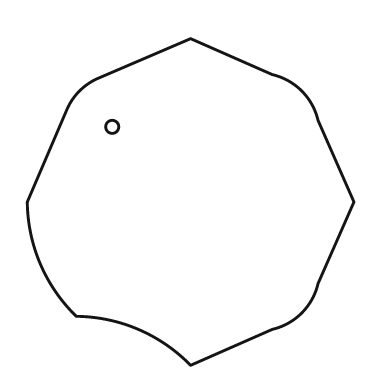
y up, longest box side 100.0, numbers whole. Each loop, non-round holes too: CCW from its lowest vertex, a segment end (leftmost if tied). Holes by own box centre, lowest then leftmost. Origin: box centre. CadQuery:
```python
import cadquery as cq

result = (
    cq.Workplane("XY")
    .moveTo(0.0, -50.0)
    .lineTo(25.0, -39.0)
    .threePointArc((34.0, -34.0), (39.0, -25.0))
    .lineTo(50.0, 0.0)
    .lineTo(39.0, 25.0)
    .threePointArc((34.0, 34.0), (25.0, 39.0))
    .lineTo(0.0, 50.0)
    .lineTo(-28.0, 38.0)
    .threePointArc((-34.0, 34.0), (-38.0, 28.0))
    .lineTo(-50.0, 0.0)
    .threePointArc((-46.0, -19.0), (-35.0, -35.0))
    .threePointArc((-16.0, -39.0), (0.0, -50.0))
    .close()
    .moveTo(-24.0, 23.0)
    .circle(2.0)
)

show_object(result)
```